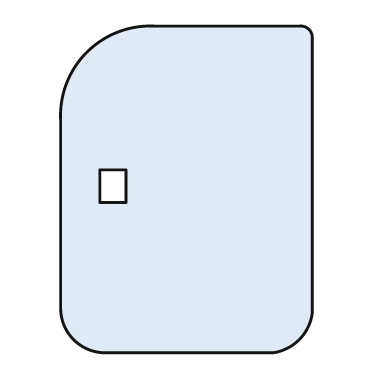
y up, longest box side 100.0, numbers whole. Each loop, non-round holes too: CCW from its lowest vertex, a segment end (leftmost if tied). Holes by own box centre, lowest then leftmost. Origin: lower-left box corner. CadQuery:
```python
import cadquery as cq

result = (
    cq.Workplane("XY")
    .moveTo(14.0, 0.0)
    .lineTo(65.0, 0.0)
    .threePointArc((73.0, 4.0), (77.0, 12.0))
    .lineTo(77.0, 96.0)
    .threePointArc((76.0, 99.0), (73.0, 100.0))
    .lineTo(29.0, 100.0)
    .threePointArc((8.0, 92.0), (0.0, 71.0))
    .lineTo(0.0, 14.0)
    .threePointArc((4.0, 4.0), (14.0, 0.0))
    .close()
    .moveTo(12.0, 46.0)
    .lineTo(20.0, 46.0)
    .lineTo(20.0, 56.0)
    .lineTo(12.0, 56.0)
    .close()
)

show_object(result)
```